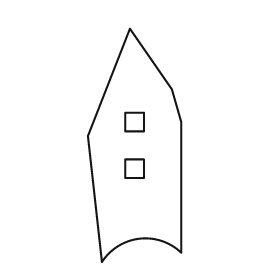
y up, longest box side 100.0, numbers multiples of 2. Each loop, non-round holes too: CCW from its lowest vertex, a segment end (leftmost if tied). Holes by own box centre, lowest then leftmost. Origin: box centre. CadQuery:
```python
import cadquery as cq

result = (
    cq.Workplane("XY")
    .moveTo(-14.0, -50.0)
    .threePointArc((2.0, -40.0), (20.0, -46.0))
    .lineTo(20.0, 10.0)
    .lineTo(16.0, 24.0)
    .lineTo(-2.0, 50.0)
    .lineTo(-20.0, 4.0)
    .close()
    .moveTo(-4.0, -14.0)
    .lineTo(4.0, -14.0)
    .lineTo(4.0, -6.0)
    .lineTo(-4.0, -6.0)
    .close()
    .moveTo(-4.0, 6.0)
    .lineTo(4.0, 6.0)
    .lineTo(4.0, 14.0)
    .lineTo(-4.0, 14.0)
    .close()
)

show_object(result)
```